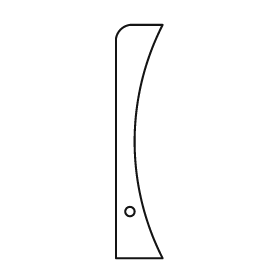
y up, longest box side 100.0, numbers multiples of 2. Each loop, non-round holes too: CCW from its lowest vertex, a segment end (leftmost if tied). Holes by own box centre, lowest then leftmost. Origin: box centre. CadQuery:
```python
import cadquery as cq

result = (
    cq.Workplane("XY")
    .moveTo(-10.0, -50.0)
    .lineTo(10.0, -50.0)
    .threePointArc((-2.0, 0.0), (10.0, 50.0))
    .lineTo(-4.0, 50.0)
    .threePointArc((-8.0, 48.0), (-10.0, 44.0))
    .close()
    .moveTo(-4.0, -30.0)
    .circle(2.0)
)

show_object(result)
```